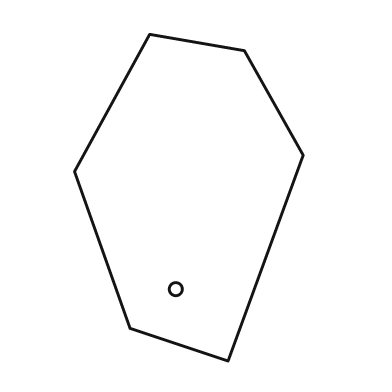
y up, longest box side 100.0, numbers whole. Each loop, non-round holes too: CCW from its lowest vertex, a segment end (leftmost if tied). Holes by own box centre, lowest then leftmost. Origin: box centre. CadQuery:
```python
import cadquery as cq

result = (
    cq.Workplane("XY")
    .moveTo(12.0, -50.0)
    .lineTo(35.0, 13.0)
    .lineTo(17.0, 45.0)
    .lineTo(-12.0, 50.0)
    .lineTo(-35.0, 8.0)
    .lineTo(-18.0, -40.0)
    .close()
    .moveTo(-4.0, -28.0)
    .circle(2.0)
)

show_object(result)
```